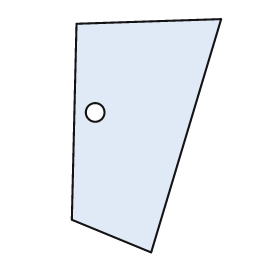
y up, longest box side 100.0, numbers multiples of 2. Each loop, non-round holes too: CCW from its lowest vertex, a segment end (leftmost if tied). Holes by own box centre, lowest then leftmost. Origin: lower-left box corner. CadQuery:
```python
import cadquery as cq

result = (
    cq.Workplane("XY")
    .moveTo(34.0, 0.0)
    .lineTo(64.0, 100.0)
    .lineTo(2.0, 98.0)
    .lineTo(0.0, 14.0)
    .close()
    .moveTo(10.0, 60.0)
    .circle(4.0)
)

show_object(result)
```